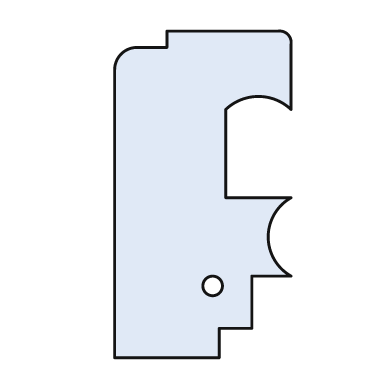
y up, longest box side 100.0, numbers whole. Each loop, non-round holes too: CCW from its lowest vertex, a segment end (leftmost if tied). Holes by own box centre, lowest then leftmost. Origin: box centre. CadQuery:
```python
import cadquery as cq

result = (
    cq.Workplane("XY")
    .moveTo(-27.0, -50.0)
    .lineTo(5.0, -50.0)
    .lineTo(5.0, -41.0)
    .lineTo(15.0, -41.0)
    .lineTo(15.0, -25.0)
    .lineTo(27.0, -25.0)
    .threePointArc((20.0, -13.0), (27.0, -1.0))
    .lineTo(7.0, -1.0)
    .lineTo(7.0, 26.0)
    .threePointArc((17.0, 30.0), (27.0, 26.0))
    .lineTo(27.0, 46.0)
    .threePointArc((26.0, 49.0), (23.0, 50.0))
    .lineTo(-11.0, 50.0)
    .lineTo(-11.0, 45.0)
    .lineTo(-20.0, 45.0)
    .threePointArc((-25.0, 43.0), (-27.0, 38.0))
    .close()
    .moveTo(3.0, -28.0)
    .circle(3.0)
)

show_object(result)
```